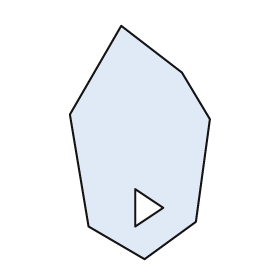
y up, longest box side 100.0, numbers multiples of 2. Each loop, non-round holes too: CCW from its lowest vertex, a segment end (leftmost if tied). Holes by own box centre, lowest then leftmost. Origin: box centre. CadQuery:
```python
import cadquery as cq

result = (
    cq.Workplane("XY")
    .moveTo(2.0, -50.0)
    .lineTo(24.0, -34.0)
    .lineTo(30.0, 10.0)
    .lineTo(18.0, 30.0)
    .lineTo(-8.0, 50.0)
    .lineTo(-30.0, 12.0)
    .lineTo(-22.0, -36.0)
    .close()
    .moveTo(-2.0, -36.0)
    .lineTo(10.0, -28.0)
    .lineTo(-2.0, -20.0)
    .close()
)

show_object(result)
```